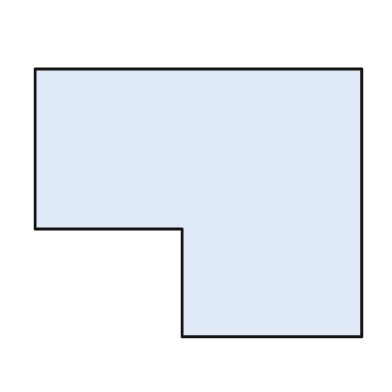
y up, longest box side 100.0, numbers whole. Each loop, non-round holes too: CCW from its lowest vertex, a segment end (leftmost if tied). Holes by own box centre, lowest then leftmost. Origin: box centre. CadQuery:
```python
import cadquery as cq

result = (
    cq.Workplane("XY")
    .moveTo(-5.0, -41.0)
    .lineTo(50.0, -41.0)
    .lineTo(50.0, 41.0)
    .lineTo(-50.0, 41.0)
    .lineTo(-50.0, -8.0)
    .lineTo(-5.0, -8.0)
    .close()
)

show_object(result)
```